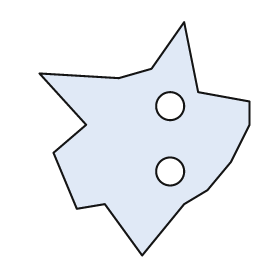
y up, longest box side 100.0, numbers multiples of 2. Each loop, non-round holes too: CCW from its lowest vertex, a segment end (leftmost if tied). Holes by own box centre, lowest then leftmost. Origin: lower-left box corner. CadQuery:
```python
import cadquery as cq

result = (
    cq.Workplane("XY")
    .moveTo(44.0, 0.0)
    .lineTo(62.0, 22.0)
    .lineTo(72.0, 28.0)
    .lineTo(82.0, 40.0)
    .lineTo(90.0, 56.0)
    .lineTo(90.0, 66.0)
    .lineTo(68.0, 70.0)
    .lineTo(62.0, 100.0)
    .lineTo(48.0, 80.0)
    .lineTo(34.0, 76.0)
    .lineTo(0.0, 78.0)
    .lineTo(20.0, 56.0)
    .lineTo(6.0, 44.0)
    .lineTo(16.0, 20.0)
    .lineTo(28.0, 22.0)
    .close()
    .moveTo(56.0, 36.0)
    .circle(6.0)
    .moveTo(56.0, 64.0)
    .circle(6.0)
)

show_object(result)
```